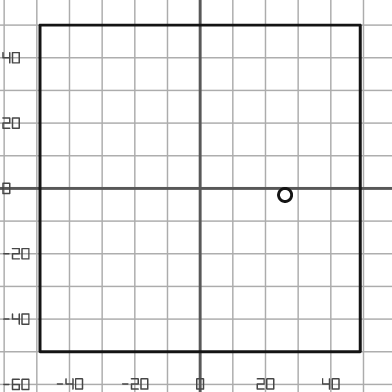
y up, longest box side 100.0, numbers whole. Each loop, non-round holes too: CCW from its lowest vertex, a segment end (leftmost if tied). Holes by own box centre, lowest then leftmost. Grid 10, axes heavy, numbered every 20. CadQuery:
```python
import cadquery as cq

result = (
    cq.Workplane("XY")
    .moveTo(-49.0, -50.0)
    .lineTo(49.0, -50.0)
    .lineTo(49.0, 50.0)
    .lineTo(-49.0, 50.0)
    .close()
    .moveTo(26.0, -2.0)
    .circle(2.0)
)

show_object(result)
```